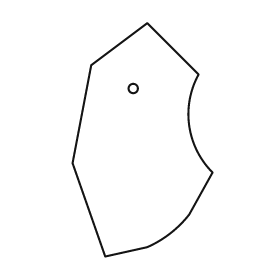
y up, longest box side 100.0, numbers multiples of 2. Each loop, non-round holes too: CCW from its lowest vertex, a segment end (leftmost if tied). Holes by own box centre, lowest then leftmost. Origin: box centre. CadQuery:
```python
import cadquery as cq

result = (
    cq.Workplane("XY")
    .moveTo(-16.0, -50.0)
    .lineTo(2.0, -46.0)
    .threePointArc((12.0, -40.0), (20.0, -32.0))
    .lineTo(30.0, -14.0)
    .threePointArc((20.0, 6.0), (24.0, 28.0))
    .lineTo(2.0, 50.0)
    .lineTo(-22.0, 32.0)
    .lineTo(-30.0, -10.0)
    .close()
    .moveTo(-4.0, 22.0)
    .circle(2.0)
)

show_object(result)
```